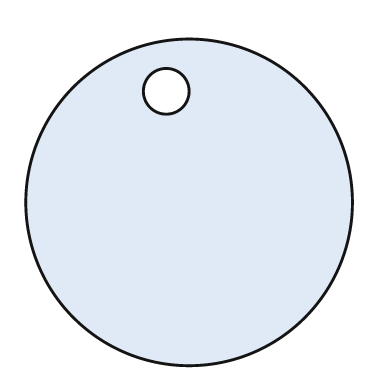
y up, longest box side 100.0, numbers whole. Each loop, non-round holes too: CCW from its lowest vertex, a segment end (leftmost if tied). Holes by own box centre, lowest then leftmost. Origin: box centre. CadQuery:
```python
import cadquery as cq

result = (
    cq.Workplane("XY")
    .moveTo(0.0, 0.0)
    .circle(50.0)
    .moveTo(-7.0, 34.0)
    .circle(7.0)
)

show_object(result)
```